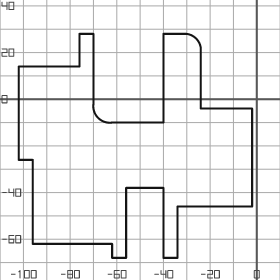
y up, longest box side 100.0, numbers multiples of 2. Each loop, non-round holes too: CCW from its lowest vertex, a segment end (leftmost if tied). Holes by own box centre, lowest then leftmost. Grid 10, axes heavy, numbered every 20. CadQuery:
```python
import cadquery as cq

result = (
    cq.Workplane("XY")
    .moveTo(-62.0, -68.0)
    .lineTo(-56.0, -68.0)
    .lineTo(-56.0, -38.0)
    .lineTo(-40.0, -38.0)
    .lineTo(-40.0, -68.0)
    .lineTo(-34.0, -68.0)
    .lineTo(-34.0, -46.0)
    .lineTo(-2.0, -46.0)
    .lineTo(-2.0, -4.0)
    .lineTo(-24.0, -4.0)
    .lineTo(-24.0, 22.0)
    .threePointArc((-26.0, 26.0), (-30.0, 28.0))
    .lineTo(-40.0, 28.0)
    .lineTo(-40.0, -10.0)
    .lineTo(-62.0, -10.0)
    .threePointArc((-68.0, -8.0), (-70.0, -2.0))
    .lineTo(-70.0, 28.0)
    .lineTo(-76.0, 28.0)
    .lineTo(-76.0, 14.0)
    .lineTo(-102.0, 14.0)
    .lineTo(-102.0, -26.0)
    .lineTo(-96.0, -26.0)
    .lineTo(-96.0, -62.0)
    .lineTo(-62.0, -62.0)
    .close()
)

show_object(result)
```